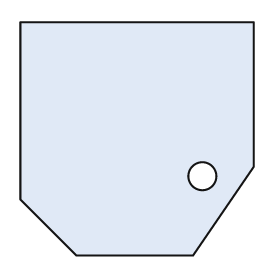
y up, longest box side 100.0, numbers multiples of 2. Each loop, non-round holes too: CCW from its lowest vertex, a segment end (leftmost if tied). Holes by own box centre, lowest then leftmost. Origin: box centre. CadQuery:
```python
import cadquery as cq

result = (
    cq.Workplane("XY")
    .moveTo(-26.0, -50.0)
    .lineTo(24.0, -50.0)
    .lineTo(50.0, -12.0)
    .lineTo(50.0, 50.0)
    .lineTo(-50.0, 50.0)
    .lineTo(-50.0, -26.0)
    .close()
    .moveTo(28.0, -16.0)
    .circle(6.0)
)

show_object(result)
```